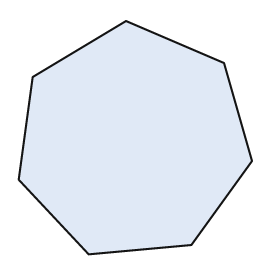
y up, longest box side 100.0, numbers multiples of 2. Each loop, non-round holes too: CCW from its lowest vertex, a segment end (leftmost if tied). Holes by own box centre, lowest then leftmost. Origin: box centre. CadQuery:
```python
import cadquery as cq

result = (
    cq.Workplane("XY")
    .moveTo(-20.0, -50.0)
    .lineTo(24.0, -46.0)
    .lineTo(50.0, -10.0)
    .lineTo(38.0, 32.0)
    .lineTo(-4.0, 50.0)
    .lineTo(-44.0, 26.0)
    .lineTo(-50.0, -18.0)
    .close()
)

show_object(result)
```